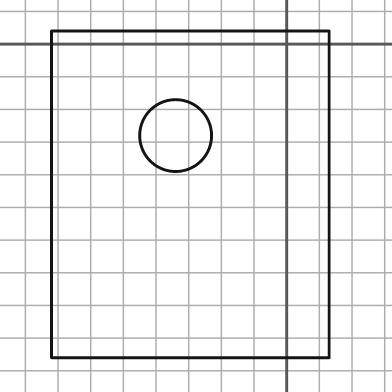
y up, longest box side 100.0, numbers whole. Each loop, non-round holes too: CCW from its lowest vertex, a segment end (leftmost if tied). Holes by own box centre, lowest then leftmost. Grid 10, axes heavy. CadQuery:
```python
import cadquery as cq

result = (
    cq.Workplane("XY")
    .moveTo(-72.0, -96.0)
    .lineTo(13.0, -96.0)
    .lineTo(13.0, 4.0)
    .lineTo(-72.0, 4.0)
    .close()
    .moveTo(-34.0, -28.0)
    .circle(11.0)
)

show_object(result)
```